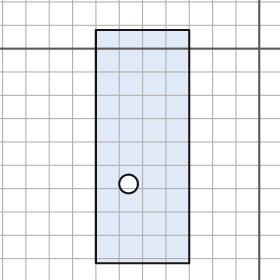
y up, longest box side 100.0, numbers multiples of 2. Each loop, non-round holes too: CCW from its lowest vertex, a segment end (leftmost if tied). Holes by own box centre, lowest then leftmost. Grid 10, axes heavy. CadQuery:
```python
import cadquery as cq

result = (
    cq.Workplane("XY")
    .moveTo(-70.0, -92.0)
    .lineTo(-30.0, -92.0)
    .lineTo(-30.0, 8.0)
    .lineTo(-70.0, 8.0)
    .close()
    .moveTo(-56.0, -58.0)
    .circle(4.0)
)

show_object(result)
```